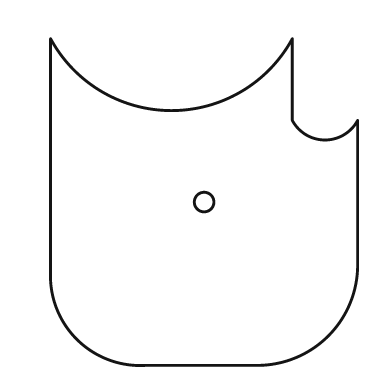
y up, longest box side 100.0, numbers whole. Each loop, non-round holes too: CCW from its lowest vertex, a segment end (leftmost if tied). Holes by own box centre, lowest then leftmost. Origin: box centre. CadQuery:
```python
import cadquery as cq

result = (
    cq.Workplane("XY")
    .moveTo(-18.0, -50.0)
    .lineTo(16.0, -50.0)
    .threePointArc((38.0, -41.0), (47.0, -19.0))
    .lineTo(47.0, 25.0)
    .threePointArc((37.0, 19.0), (27.0, 25.0))
    .lineTo(27.0, 50.0)
    .threePointArc((-10.0, 28.0), (-47.0, 50.0))
    .lineTo(-47.0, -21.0)
    .threePointArc((-39.0, -42.0), (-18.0, -50.0))
    .close()
    .moveTo(0.0, 0.0)
    .circle(3.0)
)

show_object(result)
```